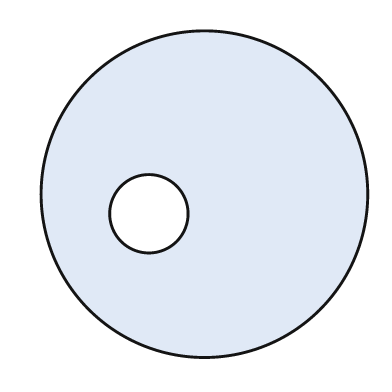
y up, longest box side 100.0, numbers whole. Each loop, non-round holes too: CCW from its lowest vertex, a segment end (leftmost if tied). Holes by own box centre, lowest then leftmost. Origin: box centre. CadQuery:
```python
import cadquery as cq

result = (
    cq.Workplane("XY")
    .moveTo(0.0, 0.0)
    .circle(50.0)
    .moveTo(-17.0, -6.0)
    .circle(12.0)
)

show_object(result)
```